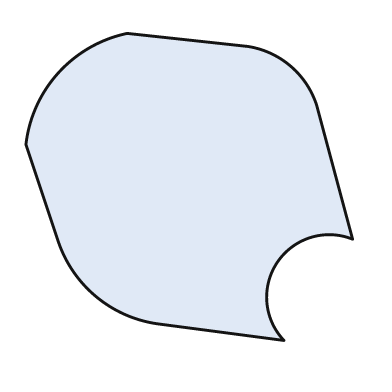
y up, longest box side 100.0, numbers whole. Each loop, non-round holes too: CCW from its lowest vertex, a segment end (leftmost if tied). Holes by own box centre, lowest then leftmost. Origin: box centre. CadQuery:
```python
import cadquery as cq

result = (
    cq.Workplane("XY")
    .moveTo(29.0, -47.0)
    .threePointArc((27.0, -23.0), (50.0, -16.0))
    .lineTo(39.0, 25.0)
    .threePointArc((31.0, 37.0), (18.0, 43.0))
    .lineTo(-19.0, 47.0)
    .threePointArc((-40.0, 35.0), (-50.0, 13.0))
    .lineTo(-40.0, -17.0)
    .threePointArc((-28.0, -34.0), (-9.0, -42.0))
    .close()
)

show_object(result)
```